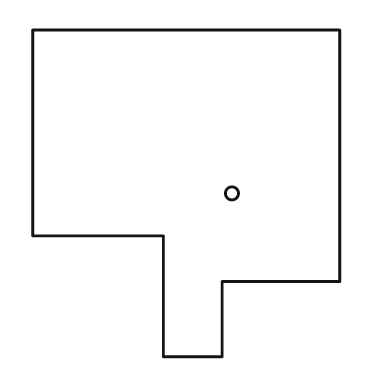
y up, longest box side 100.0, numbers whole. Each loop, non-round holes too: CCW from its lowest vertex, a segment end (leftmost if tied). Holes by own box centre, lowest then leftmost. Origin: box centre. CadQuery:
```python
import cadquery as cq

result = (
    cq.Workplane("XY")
    .moveTo(-7.0, -50.0)
    .lineTo(11.0, -50.0)
    .lineTo(11.0, -27.0)
    .lineTo(47.0, -27.0)
    .lineTo(47.0, 50.0)
    .lineTo(-47.0, 50.0)
    .lineTo(-47.0, -13.0)
    .lineTo(-7.0, -13.0)
    .close()
    .moveTo(14.0, 0.0)
    .circle(2.0)
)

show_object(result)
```